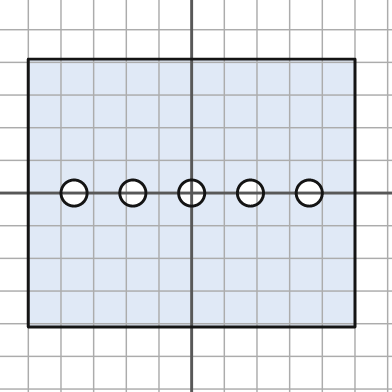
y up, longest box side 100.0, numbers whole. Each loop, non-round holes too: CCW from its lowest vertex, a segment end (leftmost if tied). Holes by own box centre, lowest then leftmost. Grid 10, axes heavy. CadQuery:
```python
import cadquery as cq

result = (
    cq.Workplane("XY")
    .moveTo(-50.0, -41.0)
    .lineTo(50.0, -41.0)
    .lineTo(50.0, 41.0)
    .lineTo(-50.0, 41.0)
    .close()
    .moveTo(-36.0, 0.0)
    .circle(4.0)
    .moveTo(-18.0, 0.0)
    .circle(4.0)
    .moveTo(0.0, 0.0)
    .circle(4.0)
    .moveTo(18.0, 0.0)
    .circle(4.0)
    .moveTo(36.0, 0.0)
    .circle(4.0)
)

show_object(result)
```